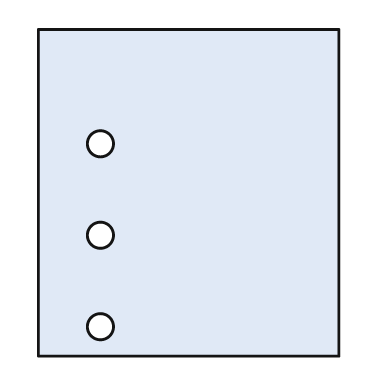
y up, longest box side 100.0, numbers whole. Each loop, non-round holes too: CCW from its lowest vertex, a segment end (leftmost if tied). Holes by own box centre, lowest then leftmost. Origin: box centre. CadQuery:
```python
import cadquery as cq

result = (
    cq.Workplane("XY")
    .moveTo(-46.0, -50.0)
    .lineTo(46.0, -50.0)
    .lineTo(46.0, 50.0)
    .lineTo(-46.0, 50.0)
    .close()
    .moveTo(-27.0, -41.0)
    .circle(4.0)
    .moveTo(-27.0, -13.0)
    .circle(4.0)
    .moveTo(-27.0, 15.0)
    .circle(4.0)
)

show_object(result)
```